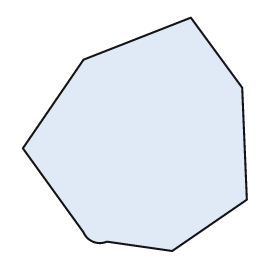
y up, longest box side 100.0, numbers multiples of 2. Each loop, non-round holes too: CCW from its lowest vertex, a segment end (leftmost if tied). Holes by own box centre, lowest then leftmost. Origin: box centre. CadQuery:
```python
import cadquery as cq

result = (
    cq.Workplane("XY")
    .moveTo(16.0, -50.0)
    .lineTo(48.0, -28.0)
    .lineTo(46.0, 20.0)
    .lineTo(24.0, 50.0)
    .lineTo(-22.0, 32.0)
    .lineTo(-48.0, -6.0)
    .lineTo(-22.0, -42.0)
    .threePointArc((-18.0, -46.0), (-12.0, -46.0))
    .close()
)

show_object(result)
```